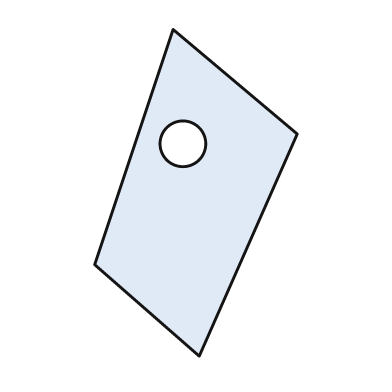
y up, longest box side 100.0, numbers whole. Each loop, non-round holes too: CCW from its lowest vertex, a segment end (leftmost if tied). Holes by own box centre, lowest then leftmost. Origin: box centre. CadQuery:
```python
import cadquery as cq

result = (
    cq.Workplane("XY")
    .moveTo(1.0, -50.0)
    .lineTo(31.0, 18.0)
    .lineTo(-7.0, 50.0)
    .lineTo(-31.0, -22.0)
    .close()
    .moveTo(-4.0, 15.0)
    .circle(7.0)
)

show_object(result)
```